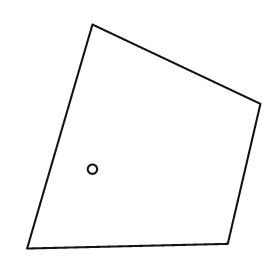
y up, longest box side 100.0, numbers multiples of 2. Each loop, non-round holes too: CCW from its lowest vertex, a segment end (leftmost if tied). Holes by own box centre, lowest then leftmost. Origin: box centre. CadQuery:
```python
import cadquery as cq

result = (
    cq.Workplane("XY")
    .moveTo(-50.0, -48.0)
    .lineTo(36.0, -46.0)
    .lineTo(50.0, 14.0)
    .lineTo(-22.0, 48.0)
    .close()
    .moveTo(-22.0, -14.0)
    .circle(2.0)
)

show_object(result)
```